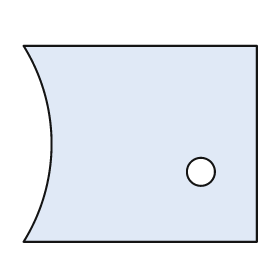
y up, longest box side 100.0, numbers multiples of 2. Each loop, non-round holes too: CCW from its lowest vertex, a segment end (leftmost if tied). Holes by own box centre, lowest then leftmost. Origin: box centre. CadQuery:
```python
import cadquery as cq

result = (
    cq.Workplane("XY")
    .moveTo(-50.0, -42.0)
    .lineTo(50.0, -42.0)
    .lineTo(50.0, 42.0)
    .lineTo(-50.0, 42.0)
    .threePointArc((-38.0, 0.0), (-50.0, -42.0))
    .close()
    .moveTo(26.0, -12.0)
    .circle(6.0)
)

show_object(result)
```